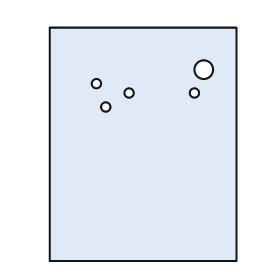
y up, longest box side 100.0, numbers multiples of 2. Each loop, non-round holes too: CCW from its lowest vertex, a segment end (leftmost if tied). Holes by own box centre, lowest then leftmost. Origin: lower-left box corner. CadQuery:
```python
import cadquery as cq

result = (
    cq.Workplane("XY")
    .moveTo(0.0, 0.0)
    .lineTo(80.0, 0.0)
    .lineTo(80.0, 100.0)
    .lineTo(0.0, 100.0)
    .close()
    .moveTo(24.0, 66.0)
    .circle(2.0)
    .moveTo(34.0, 72.0)
    .circle(2.0)
    .moveTo(62.0, 72.0)
    .circle(2.0)
    .moveTo(20.0, 76.0)
    .circle(2.0)
    .moveTo(66.0, 82.0)
    .circle(4.0)
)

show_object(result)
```